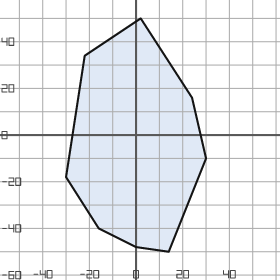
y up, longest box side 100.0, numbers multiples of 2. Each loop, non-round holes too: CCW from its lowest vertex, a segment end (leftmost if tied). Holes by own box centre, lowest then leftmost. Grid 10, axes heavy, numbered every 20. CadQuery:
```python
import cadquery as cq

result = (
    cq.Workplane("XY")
    .moveTo(14.0, -50.0)
    .lineTo(30.0, -10.0)
    .lineTo(24.0, 16.0)
    .lineTo(2.0, 50.0)
    .lineTo(-22.0, 34.0)
    .lineTo(-30.0, -18.0)
    .lineTo(-16.0, -40.0)
    .lineTo(0.0, -48.0)
    .close()
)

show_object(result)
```